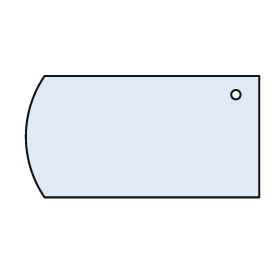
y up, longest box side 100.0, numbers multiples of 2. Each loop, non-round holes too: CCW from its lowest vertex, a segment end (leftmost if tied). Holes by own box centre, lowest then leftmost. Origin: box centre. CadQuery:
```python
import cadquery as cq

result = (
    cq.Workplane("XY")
    .moveTo(-42.0, -26.0)
    .lineTo(50.0, -26.0)
    .lineTo(50.0, 26.0)
    .lineTo(-42.0, 26.0)
    .threePointArc((-50.0, 0.0), (-42.0, -26.0))
    .close()
    .moveTo(40.0, 18.0)
    .circle(2.0)
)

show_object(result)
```